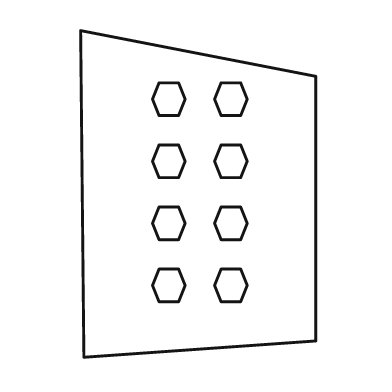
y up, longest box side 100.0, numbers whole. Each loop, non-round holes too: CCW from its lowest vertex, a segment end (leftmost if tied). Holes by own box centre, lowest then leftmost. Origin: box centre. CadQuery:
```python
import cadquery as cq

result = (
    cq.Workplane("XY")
    .moveTo(-35.0, -50.0)
    .lineTo(36.0, -45.0)
    .lineTo(36.0, 36.0)
    .lineTo(-36.0, 50.0)
    .close()
    .moveTo(-12.0, -33.0)
    .lineTo(-6.0, -33.0)
    .lineTo(-4.0, -28.0)
    .lineTo(-6.0, -23.0)
    .lineTo(-12.0, -23.0)
    .lineTo(-14.0, -28.0)
    .close()
    .moveTo(7.0, -33.0)
    .lineTo(13.0, -33.0)
    .lineTo(15.0, -28.0)
    .lineTo(13.0, -23.0)
    .lineTo(7.0, -23.0)
    .lineTo(5.0, -28.0)
    .close()
    .moveTo(-12.0, -14.0)
    .lineTo(-6.0, -14.0)
    .lineTo(-4.0, -9.0)
    .lineTo(-6.0, -4.0)
    .lineTo(-12.0, -4.0)
    .lineTo(-14.0, -9.0)
    .close()
    .moveTo(7.0, -14.0)
    .lineTo(13.0, -14.0)
    .lineTo(15.0, -9.0)
    .lineTo(13.0, -4.0)
    .lineTo(7.0, -4.0)
    .lineTo(5.0, -9.0)
    .close()
    .moveTo(-12.0, 5.0)
    .lineTo(-6.0, 5.0)
    .lineTo(-4.0, 10.0)
    .lineTo(-6.0, 15.0)
    .lineTo(-12.0, 15.0)
    .lineTo(-14.0, 10.0)
    .close()
    .moveTo(7.0, 5.0)
    .lineTo(13.0, 5.0)
    .lineTo(15.0, 10.0)
    .lineTo(13.0, 15.0)
    .lineTo(7.0, 15.0)
    .lineTo(5.0, 10.0)
    .close()
    .moveTo(-12.0, 24.0)
    .lineTo(-6.0, 24.0)
    .lineTo(-4.0, 29.0)
    .lineTo(-6.0, 34.0)
    .lineTo(-12.0, 34.0)
    .lineTo(-14.0, 29.0)
    .close()
    .moveTo(7.0, 24.0)
    .lineTo(13.0, 24.0)
    .lineTo(15.0, 29.0)
    .lineTo(13.0, 34.0)
    .lineTo(7.0, 34.0)
    .lineTo(5.0, 29.0)
    .close()
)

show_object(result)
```